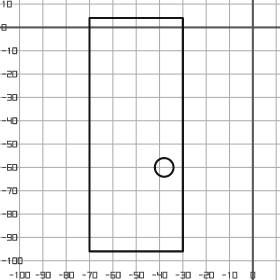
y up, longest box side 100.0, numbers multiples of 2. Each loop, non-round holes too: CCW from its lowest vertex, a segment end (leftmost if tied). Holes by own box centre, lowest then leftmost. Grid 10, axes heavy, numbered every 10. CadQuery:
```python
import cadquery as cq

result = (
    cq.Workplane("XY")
    .moveTo(-70.0, -96.0)
    .lineTo(-30.0, -96.0)
    .lineTo(-30.0, 4.0)
    .lineTo(-70.0, 4.0)
    .close()
    .moveTo(-38.0, -60.0)
    .circle(4.0)
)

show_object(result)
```